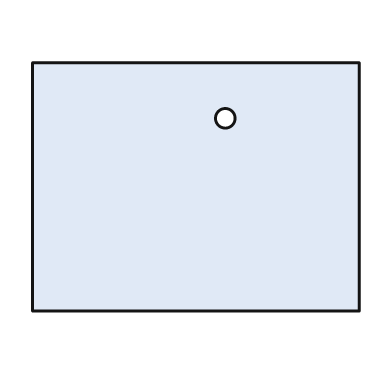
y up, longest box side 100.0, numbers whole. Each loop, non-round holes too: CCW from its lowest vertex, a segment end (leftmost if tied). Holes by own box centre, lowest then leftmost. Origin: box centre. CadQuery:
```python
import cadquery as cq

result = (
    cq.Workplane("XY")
    .moveTo(-50.0, -38.0)
    .lineTo(50.0, -38.0)
    .lineTo(50.0, 38.0)
    .lineTo(-50.0, 38.0)
    .close()
    .moveTo(9.0, 21.0)
    .circle(3.0)
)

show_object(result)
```